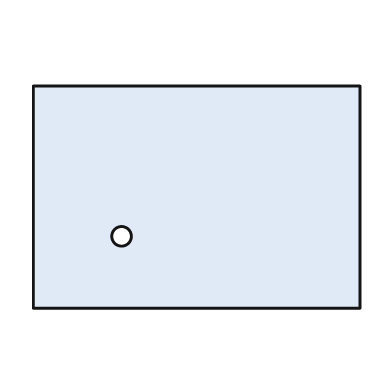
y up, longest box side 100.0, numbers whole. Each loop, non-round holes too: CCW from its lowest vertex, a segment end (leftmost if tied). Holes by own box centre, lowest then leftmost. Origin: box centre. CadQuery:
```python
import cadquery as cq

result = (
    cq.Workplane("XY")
    .moveTo(-50.0, -34.0)
    .lineTo(50.0, -34.0)
    .lineTo(50.0, 34.0)
    .lineTo(-50.0, 34.0)
    .close()
    .moveTo(-23.0, -12.0)
    .circle(3.0)
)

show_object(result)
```